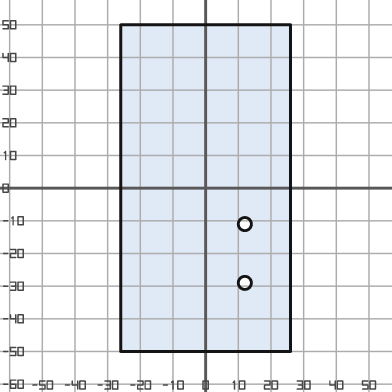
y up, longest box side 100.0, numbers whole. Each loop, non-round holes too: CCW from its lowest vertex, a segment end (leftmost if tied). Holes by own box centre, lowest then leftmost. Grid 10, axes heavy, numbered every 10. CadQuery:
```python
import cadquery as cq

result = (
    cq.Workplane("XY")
    .moveTo(-26.0, -50.0)
    .lineTo(26.0, -50.0)
    .lineTo(26.0, 50.0)
    .lineTo(-26.0, 50.0)
    .close()
    .moveTo(12.0, -29.0)
    .circle(2.0)
    .moveTo(12.0, -11.0)
    .circle(2.0)
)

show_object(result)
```